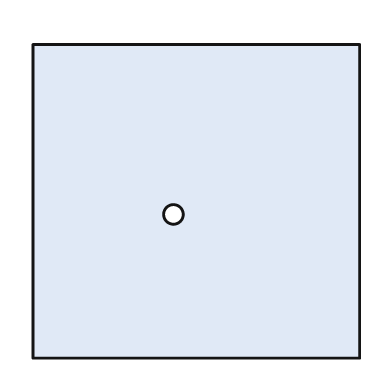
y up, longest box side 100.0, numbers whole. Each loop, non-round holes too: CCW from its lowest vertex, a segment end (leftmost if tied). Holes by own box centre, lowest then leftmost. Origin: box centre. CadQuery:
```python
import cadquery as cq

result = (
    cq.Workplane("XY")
    .moveTo(-50.0, -48.0)
    .lineTo(50.0, -48.0)
    .lineTo(50.0, 48.0)
    .lineTo(-50.0, 48.0)
    .close()
    .moveTo(-7.0, -4.0)
    .circle(3.0)
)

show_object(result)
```